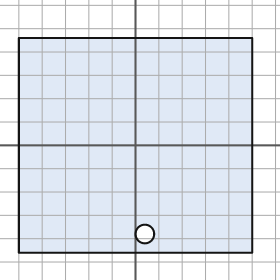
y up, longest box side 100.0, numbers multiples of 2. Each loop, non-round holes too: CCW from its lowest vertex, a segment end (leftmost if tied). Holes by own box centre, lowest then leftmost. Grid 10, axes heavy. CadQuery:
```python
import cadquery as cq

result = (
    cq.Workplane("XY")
    .moveTo(-50.0, -46.0)
    .lineTo(50.0, -46.0)
    .lineTo(50.0, 46.0)
    .lineTo(-50.0, 46.0)
    .close()
    .moveTo(4.0, -38.0)
    .circle(4.0)
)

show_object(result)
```